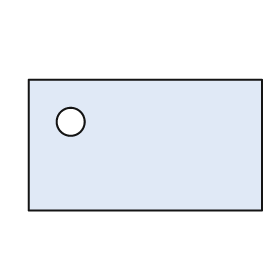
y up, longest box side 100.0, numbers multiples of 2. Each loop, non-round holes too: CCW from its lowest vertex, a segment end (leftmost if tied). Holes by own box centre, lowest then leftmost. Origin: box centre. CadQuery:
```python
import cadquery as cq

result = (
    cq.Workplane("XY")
    .moveTo(-50.0, -28.0)
    .lineTo(50.0, -28.0)
    .lineTo(50.0, 28.0)
    .lineTo(-50.0, 28.0)
    .close()
    .moveTo(-32.0, 10.0)
    .circle(6.0)
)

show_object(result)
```